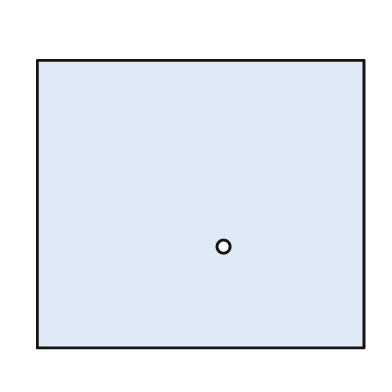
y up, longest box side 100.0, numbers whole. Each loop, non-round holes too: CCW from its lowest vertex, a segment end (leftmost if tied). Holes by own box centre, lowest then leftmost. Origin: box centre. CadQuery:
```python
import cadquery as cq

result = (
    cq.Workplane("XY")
    .moveTo(-50.0, -44.0)
    .lineTo(50.0, -44.0)
    .lineTo(50.0, 44.0)
    .lineTo(-50.0, 44.0)
    .close()
    .moveTo(7.0, -13.0)
    .circle(2.0)
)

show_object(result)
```